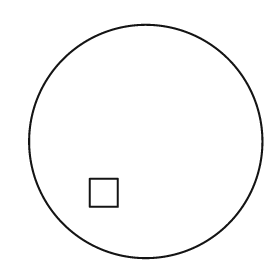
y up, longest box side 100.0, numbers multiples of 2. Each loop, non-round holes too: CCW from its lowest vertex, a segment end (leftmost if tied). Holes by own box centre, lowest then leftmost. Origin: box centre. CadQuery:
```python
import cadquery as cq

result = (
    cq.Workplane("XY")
    .moveTo(0.0, 0.0)
    .circle(50.0)
    .moveTo(-24.0, -28.0)
    .lineTo(-12.0, -28.0)
    .lineTo(-12.0, -16.0)
    .lineTo(-24.0, -16.0)
    .close()
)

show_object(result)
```